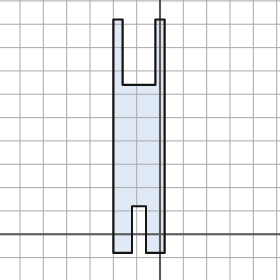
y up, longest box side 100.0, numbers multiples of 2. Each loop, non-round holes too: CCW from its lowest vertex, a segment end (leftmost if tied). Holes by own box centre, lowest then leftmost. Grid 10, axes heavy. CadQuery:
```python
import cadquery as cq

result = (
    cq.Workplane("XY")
    .moveTo(-20.0, -8.0)
    .lineTo(-12.0, -8.0)
    .lineTo(-12.0, 12.0)
    .lineTo(-6.0, 12.0)
    .lineTo(-6.0, -8.0)
    .lineTo(2.0, -8.0)
    .lineTo(2.0, 92.0)
    .lineTo(-2.0, 92.0)
    .lineTo(-2.0, 64.0)
    .lineTo(-16.0, 64.0)
    .lineTo(-16.0, 92.0)
    .lineTo(-20.0, 92.0)
    .close()
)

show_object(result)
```